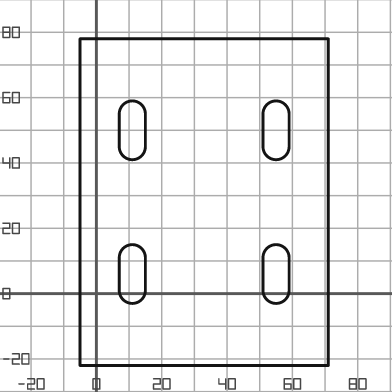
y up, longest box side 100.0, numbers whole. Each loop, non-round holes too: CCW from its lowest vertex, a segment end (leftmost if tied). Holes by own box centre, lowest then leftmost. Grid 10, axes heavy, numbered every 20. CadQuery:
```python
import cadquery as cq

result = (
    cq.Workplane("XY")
    .moveTo(-5.0, -22.0)
    .lineTo(71.0, -22.0)
    .lineTo(71.0, 78.0)
    .lineTo(-5.0, 78.0)
    .close()
    .moveTo(7.0, 1.0)
    .threePointArc((11.0, -3.0), (15.0, 1.0))
    .lineTo(15.0, 11.0)
    .threePointArc((11.0, 15.0), (7.0, 11.0))
    .close()
    .moveTo(51.0, 1.0)
    .threePointArc((55.0, -3.0), (59.0, 1.0))
    .lineTo(59.0, 11.0)
    .threePointArc((55.0, 15.0), (51.0, 11.0))
    .close()
    .moveTo(7.0, 45.0)
    .threePointArc((11.0, 41.0), (15.0, 45.0))
    .lineTo(15.0, 55.0)
    .threePointArc((11.0, 59.0), (7.0, 55.0))
    .close()
    .moveTo(51.0, 45.0)
    .threePointArc((55.0, 41.0), (59.0, 45.0))
    .lineTo(59.0, 55.0)
    .threePointArc((55.0, 59.0), (51.0, 55.0))
    .close()
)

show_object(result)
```